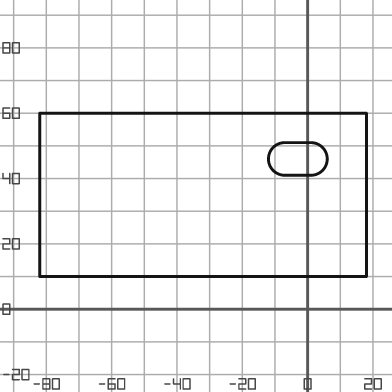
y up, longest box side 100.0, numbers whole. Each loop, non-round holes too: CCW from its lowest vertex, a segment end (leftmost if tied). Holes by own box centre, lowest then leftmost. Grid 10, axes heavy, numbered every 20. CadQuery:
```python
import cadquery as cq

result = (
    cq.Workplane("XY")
    .moveTo(-82.0, 10.0)
    .lineTo(18.0, 10.0)
    .lineTo(18.0, 60.0)
    .lineTo(-82.0, 60.0)
    .close()
    .moveTo(-7.0, 41.0)
    .lineTo(1.0, 41.0)
    .threePointArc((6.0, 46.0), (1.0, 51.0))
    .lineTo(-7.0, 51.0)
    .threePointArc((-12.0, 46.0), (-7.0, 41.0))
    .close()
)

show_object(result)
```